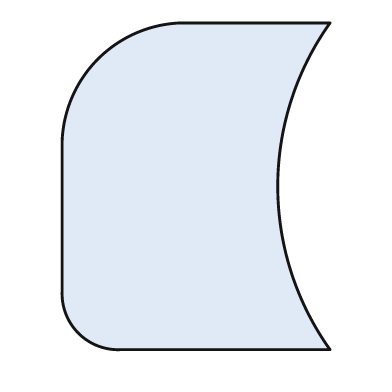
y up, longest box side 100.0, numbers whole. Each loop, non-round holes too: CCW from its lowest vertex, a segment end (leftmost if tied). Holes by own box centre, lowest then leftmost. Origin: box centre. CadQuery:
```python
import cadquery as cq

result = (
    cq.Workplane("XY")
    .moveTo(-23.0, -50.0)
    .lineTo(41.0, -50.0)
    .threePointArc((25.0, 0.0), (41.0, 50.0))
    .lineTo(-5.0, 50.0)
    .threePointArc((-30.0, 39.0), (-41.0, 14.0))
    .lineTo(-41.0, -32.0)
    .threePointArc((-36.0, -45.0), (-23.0, -50.0))
    .close()
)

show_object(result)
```